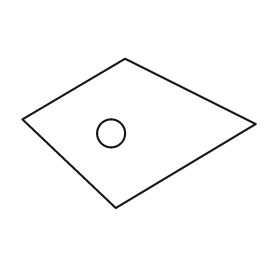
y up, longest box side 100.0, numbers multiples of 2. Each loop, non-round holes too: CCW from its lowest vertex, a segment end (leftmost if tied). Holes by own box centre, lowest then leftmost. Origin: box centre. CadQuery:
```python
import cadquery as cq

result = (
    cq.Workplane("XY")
    .moveTo(-10.0, -32.0)
    .lineTo(50.0, 4.0)
    .lineTo(-6.0, 32.0)
    .lineTo(-50.0, 6.0)
    .close()
    .moveTo(-12.0, 0.0)
    .circle(6.0)
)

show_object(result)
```